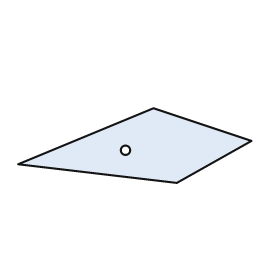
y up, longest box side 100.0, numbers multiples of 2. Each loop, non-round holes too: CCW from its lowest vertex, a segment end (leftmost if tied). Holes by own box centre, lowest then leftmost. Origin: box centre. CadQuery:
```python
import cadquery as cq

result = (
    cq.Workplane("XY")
    .moveTo(18.0, -16.0)
    .lineTo(50.0, 2.0)
    .lineTo(8.0, 16.0)
    .lineTo(-50.0, -8.0)
    .close()
    .moveTo(-4.0, -2.0)
    .circle(2.0)
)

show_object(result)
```